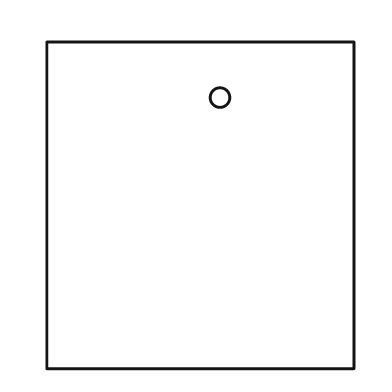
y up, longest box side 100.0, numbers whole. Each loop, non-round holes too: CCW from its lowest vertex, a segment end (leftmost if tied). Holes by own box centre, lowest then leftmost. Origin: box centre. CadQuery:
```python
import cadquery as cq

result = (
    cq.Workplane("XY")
    .moveTo(-47.0, -50.0)
    .lineTo(47.0, -50.0)
    .lineTo(47.0, 50.0)
    .lineTo(-47.0, 50.0)
    .close()
    .moveTo(6.0, 33.0)
    .circle(3.0)
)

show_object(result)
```